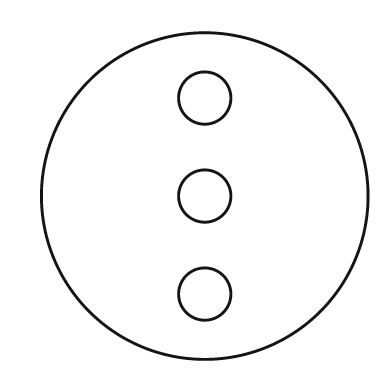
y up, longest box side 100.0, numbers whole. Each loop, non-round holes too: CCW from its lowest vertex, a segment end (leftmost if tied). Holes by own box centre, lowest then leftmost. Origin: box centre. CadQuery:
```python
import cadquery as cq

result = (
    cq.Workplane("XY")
    .moveTo(0.0, 0.0)
    .circle(50.0)
    .moveTo(0.0, -30.0)
    .circle(8.0)
    .moveTo(0.0, 0.0)
    .circle(8.0)
    .moveTo(0.0, 30.0)
    .circle(8.0)
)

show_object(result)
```